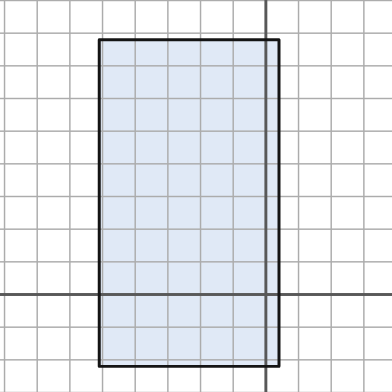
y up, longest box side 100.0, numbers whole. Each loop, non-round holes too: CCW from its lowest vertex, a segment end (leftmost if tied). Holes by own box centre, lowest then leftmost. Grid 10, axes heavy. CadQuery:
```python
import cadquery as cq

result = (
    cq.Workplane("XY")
    .moveTo(-51.0, -22.0)
    .lineTo(4.0, -22.0)
    .lineTo(4.0, 78.0)
    .lineTo(-51.0, 78.0)
    .close()
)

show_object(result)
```